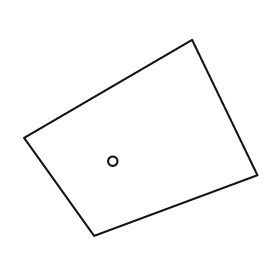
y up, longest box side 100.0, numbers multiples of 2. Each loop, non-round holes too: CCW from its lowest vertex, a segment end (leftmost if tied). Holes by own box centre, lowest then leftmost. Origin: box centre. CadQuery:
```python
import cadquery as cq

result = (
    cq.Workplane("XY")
    .moveTo(-20.0, -42.0)
    .lineTo(50.0, -16.0)
    .lineTo(22.0, 42.0)
    .lineTo(-50.0, 0.0)
    .close()
    .moveTo(-12.0, -10.0)
    .circle(2.0)
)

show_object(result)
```